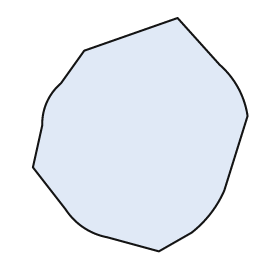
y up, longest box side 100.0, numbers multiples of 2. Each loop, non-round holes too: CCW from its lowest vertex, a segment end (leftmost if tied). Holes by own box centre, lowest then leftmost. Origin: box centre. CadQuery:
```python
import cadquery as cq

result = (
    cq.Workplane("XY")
    .moveTo(8.0, -50.0)
    .lineTo(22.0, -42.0)
    .threePointArc((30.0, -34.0), (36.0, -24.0))
    .lineTo(46.0, 8.0)
    .threePointArc((42.0, 20.0), (34.0, 30.0))
    .lineTo(16.0, 50.0)
    .lineTo(-24.0, 36.0)
    .lineTo(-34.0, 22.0)
    .threePointArc((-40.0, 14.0), (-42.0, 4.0))
    .lineTo(-46.0, -14.0)
    .lineTo(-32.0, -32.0)
    .threePointArc((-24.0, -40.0), (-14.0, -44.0))
    .close()
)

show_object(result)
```